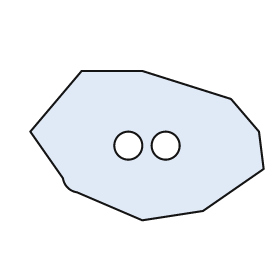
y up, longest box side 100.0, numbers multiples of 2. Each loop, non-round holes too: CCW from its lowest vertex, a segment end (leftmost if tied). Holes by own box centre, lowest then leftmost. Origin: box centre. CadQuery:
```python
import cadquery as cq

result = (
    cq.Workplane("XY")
    .moveTo(-2.0, -32.0)
    .lineTo(24.0, -28.0)
    .lineTo(50.0, -10.0)
    .lineTo(48.0, 6.0)
    .lineTo(36.0, 20.0)
    .lineTo(-2.0, 32.0)
    .lineTo(-28.0, 32.0)
    .lineTo(-50.0, 6.0)
    .lineTo(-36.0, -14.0)
    .threePointArc((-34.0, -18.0), (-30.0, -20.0))
    .close()
    .moveTo(-8.0, 0.0)
    .circle(6.0)
    .moveTo(8.0, 0.0)
    .circle(6.0)
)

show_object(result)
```